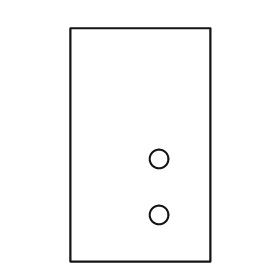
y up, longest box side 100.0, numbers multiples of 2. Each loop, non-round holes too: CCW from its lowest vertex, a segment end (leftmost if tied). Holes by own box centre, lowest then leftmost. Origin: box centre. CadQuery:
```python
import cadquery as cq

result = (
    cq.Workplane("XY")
    .moveTo(-30.0, -50.0)
    .lineTo(30.0, -50.0)
    .lineTo(30.0, 50.0)
    .lineTo(-30.0, 50.0)
    .close()
    .moveTo(8.0, -30.0)
    .circle(4.0)
    .moveTo(8.0, -6.0)
    .circle(4.0)
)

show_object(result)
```